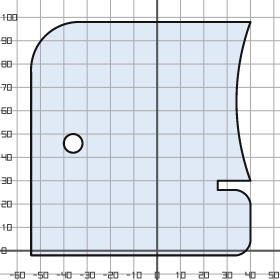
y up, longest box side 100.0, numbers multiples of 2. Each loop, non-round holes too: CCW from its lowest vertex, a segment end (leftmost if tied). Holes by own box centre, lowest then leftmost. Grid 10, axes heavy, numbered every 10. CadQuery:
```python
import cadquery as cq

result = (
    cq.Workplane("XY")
    .moveTo(-54.0, -2.0)
    .lineTo(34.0, -2.0)
    .threePointArc((38.0, 0.0), (40.0, 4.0))
    .lineTo(40.0, 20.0)
    .threePointArc((38.0, 24.0), (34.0, 26.0))
    .lineTo(26.0, 26.0)
    .lineTo(26.0, 30.0)
    .lineTo(40.0, 30.0)
    .threePointArc((34.0, 64.0), (40.0, 98.0))
    .lineTo(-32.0, 98.0)
    .threePointArc((-48.0, 92.0), (-54.0, 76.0))
    .close()
    .moveTo(-36.0, 46.0)
    .circle(4.0)
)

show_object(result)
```